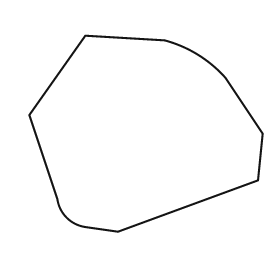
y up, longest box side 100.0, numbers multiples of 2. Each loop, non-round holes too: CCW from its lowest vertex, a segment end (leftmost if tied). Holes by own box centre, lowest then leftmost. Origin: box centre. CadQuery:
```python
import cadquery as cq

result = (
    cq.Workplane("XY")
    .moveTo(-12.0, -42.0)
    .lineTo(48.0, -20.0)
    .lineTo(50.0, 0.0)
    .lineTo(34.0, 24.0)
    .threePointArc((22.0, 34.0), (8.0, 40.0))
    .lineTo(-26.0, 42.0)
    .lineTo(-50.0, 8.0)
    .lineTo(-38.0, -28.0)
    .threePointArc((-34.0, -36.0), (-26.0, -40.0))
    .close()
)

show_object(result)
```